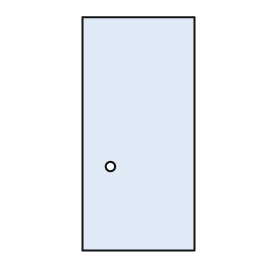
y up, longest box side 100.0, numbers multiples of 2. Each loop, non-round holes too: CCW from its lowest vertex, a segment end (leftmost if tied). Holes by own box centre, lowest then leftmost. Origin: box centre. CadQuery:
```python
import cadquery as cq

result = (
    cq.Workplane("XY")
    .moveTo(-24.0, -50.0)
    .lineTo(24.0, -50.0)
    .lineTo(24.0, 50.0)
    .lineTo(-24.0, 50.0)
    .close()
    .moveTo(-12.0, -14.0)
    .circle(2.0)
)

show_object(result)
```